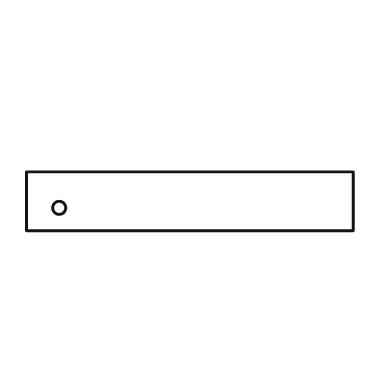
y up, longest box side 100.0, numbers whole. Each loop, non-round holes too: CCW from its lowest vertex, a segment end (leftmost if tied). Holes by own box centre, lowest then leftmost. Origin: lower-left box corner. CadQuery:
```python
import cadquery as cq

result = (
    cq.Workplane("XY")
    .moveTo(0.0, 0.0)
    .lineTo(100.0, 0.0)
    .lineTo(100.0, 18.0)
    .lineTo(0.0, 18.0)
    .close()
    .moveTo(10.0, 7.0)
    .circle(2.0)
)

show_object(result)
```